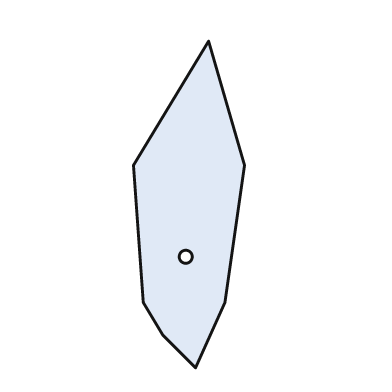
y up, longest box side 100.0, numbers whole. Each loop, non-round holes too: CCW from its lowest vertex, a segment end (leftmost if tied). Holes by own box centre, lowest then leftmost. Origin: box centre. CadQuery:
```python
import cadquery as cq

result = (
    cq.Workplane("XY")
    .moveTo(2.0, -50.0)
    .lineTo(11.0, -30.0)
    .lineTo(17.0, 12.0)
    .lineTo(6.0, 50.0)
    .lineTo(-17.0, 12.0)
    .lineTo(-14.0, -30.0)
    .lineTo(-8.0, -40.0)
    .close()
    .moveTo(-1.0, -16.0)
    .circle(2.0)
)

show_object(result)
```